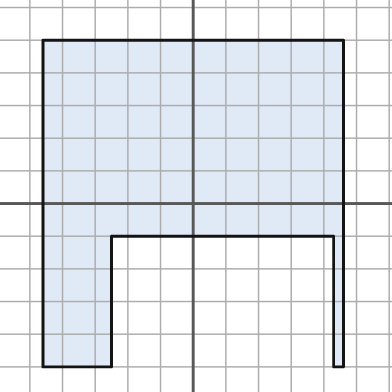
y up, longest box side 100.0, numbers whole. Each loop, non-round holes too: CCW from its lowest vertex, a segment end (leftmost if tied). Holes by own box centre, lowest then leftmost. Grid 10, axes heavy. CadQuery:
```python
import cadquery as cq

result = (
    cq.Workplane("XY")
    .moveTo(-46.0, -50.0)
    .lineTo(-25.0, -50.0)
    .lineTo(-25.0, -10.0)
    .lineTo(43.0, -10.0)
    .lineTo(43.0, -50.0)
    .lineTo(46.0, -50.0)
    .lineTo(46.0, 50.0)
    .lineTo(-46.0, 50.0)
    .close()
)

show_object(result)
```